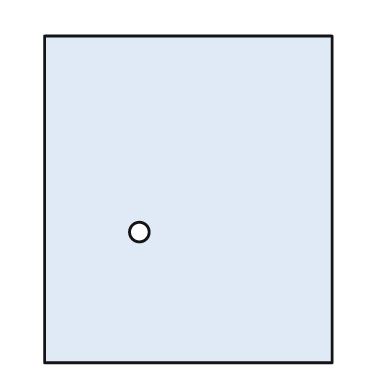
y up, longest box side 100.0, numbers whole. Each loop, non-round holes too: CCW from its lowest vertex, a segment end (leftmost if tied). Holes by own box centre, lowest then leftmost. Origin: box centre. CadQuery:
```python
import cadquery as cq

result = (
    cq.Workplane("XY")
    .moveTo(-44.0, -50.0)
    .lineTo(44.0, -50.0)
    .lineTo(44.0, 50.0)
    .lineTo(-44.0, 50.0)
    .close()
    .moveTo(-15.0, -10.0)
    .circle(3.0)
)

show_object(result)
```